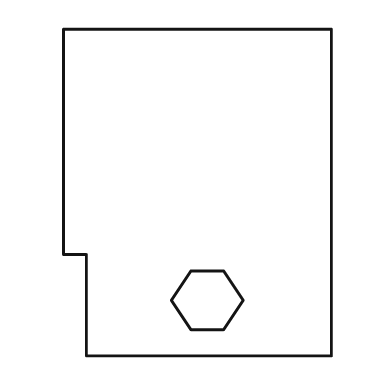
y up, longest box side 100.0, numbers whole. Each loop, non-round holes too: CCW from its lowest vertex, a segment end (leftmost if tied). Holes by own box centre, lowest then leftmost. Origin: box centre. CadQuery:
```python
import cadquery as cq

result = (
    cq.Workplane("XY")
    .moveTo(-34.0, -50.0)
    .lineTo(41.0, -50.0)
    .lineTo(41.0, 50.0)
    .lineTo(-41.0, 50.0)
    .lineTo(-41.0, -19.0)
    .lineTo(-34.0, -19.0)
    .close()
    .moveTo(-2.0, -42.0)
    .lineTo(8.0, -42.0)
    .lineTo(14.0, -33.0)
    .lineTo(8.0, -24.0)
    .lineTo(-2.0, -24.0)
    .lineTo(-8.0, -33.0)
    .close()
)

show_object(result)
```